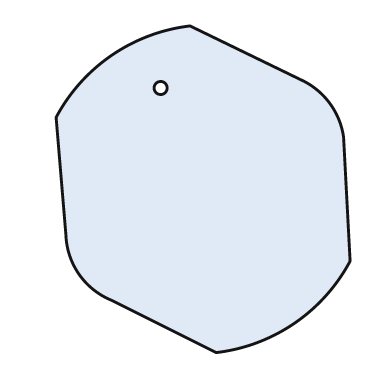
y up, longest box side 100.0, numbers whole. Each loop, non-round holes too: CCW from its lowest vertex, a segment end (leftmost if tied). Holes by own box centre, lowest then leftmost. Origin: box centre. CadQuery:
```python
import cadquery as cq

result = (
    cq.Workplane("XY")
    .moveTo(4.0, -50.0)
    .threePointArc((28.0, -41.0), (45.0, -22.0))
    .lineTo(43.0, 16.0)
    .threePointArc((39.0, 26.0), (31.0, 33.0))
    .lineTo(-4.0, 50.0)
    .threePointArc((-28.0, 41.0), (-45.0, 22.0))
    .lineTo(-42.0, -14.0)
    .threePointArc((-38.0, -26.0), (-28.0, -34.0))
    .close()
    .moveTo(-13.0, 31.0)
    .circle(2.0)
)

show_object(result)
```